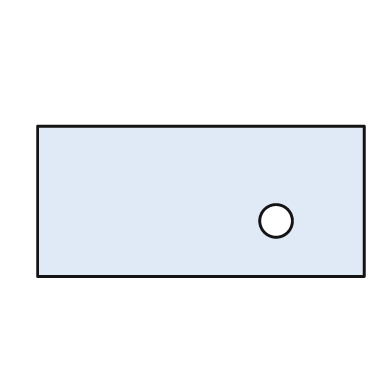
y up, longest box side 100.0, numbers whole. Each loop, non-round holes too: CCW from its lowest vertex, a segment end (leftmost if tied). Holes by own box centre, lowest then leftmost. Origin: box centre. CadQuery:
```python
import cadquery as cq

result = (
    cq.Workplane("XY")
    .moveTo(-50.0, -23.0)
    .lineTo(50.0, -23.0)
    .lineTo(50.0, 23.0)
    .lineTo(-50.0, 23.0)
    .close()
    .moveTo(23.0, -6.0)
    .circle(5.0)
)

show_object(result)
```